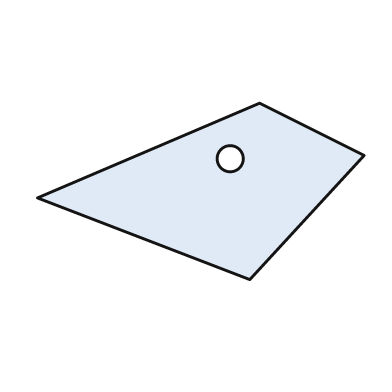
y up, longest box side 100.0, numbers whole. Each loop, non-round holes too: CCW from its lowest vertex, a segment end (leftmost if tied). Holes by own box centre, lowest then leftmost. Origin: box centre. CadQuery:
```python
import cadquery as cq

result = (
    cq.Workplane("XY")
    .moveTo(15.0, -27.0)
    .lineTo(50.0, 11.0)
    .lineTo(18.0, 27.0)
    .lineTo(-50.0, -2.0)
    .close()
    .moveTo(9.0, 10.0)
    .circle(4.0)
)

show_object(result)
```